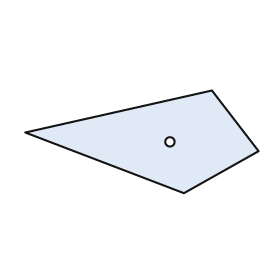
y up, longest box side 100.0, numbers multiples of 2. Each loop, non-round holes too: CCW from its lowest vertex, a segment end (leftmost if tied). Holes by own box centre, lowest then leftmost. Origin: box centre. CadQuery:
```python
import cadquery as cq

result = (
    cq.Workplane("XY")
    .moveTo(18.0, -22.0)
    .lineTo(50.0, -4.0)
    .lineTo(30.0, 22.0)
    .lineTo(-50.0, 4.0)
    .close()
    .moveTo(12.0, 0.0)
    .circle(2.0)
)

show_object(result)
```